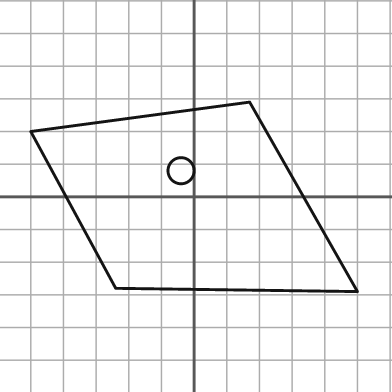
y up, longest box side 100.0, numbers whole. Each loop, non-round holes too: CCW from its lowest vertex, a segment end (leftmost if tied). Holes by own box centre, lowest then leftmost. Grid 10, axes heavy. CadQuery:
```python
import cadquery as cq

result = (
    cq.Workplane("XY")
    .moveTo(50.0, -29.0)
    .lineTo(17.0, 29.0)
    .lineTo(-50.0, 20.0)
    .lineTo(-24.0, -28.0)
    .close()
    .moveTo(-4.0, 8.0)
    .circle(4.0)
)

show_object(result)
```